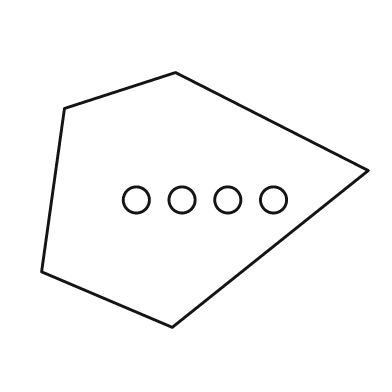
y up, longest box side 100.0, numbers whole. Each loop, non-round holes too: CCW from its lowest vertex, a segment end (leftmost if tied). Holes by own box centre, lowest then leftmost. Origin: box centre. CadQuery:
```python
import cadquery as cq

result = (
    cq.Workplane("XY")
    .moveTo(-10.0, -39.0)
    .lineTo(50.0, 9.0)
    .lineTo(-9.0, 39.0)
    .lineTo(-43.0, 28.0)
    .lineTo(-50.0, -22.0)
    .close()
    .moveTo(-21.0, 0.0)
    .circle(4.0)
    .moveTo(-7.0, 0.0)
    .circle(4.0)
    .moveTo(7.0, 0.0)
    .circle(4.0)
    .moveTo(21.0, 0.0)
    .circle(4.0)
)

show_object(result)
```